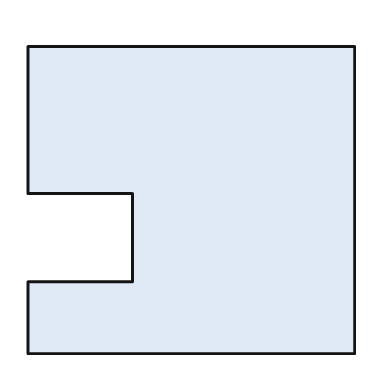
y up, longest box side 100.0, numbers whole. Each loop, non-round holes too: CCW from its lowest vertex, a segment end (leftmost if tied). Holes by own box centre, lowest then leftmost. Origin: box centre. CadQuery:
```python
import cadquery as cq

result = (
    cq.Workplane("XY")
    .moveTo(-50.0, -47.0)
    .lineTo(50.0, -47.0)
    .lineTo(50.0, 47.0)
    .lineTo(-50.0, 47.0)
    .lineTo(-50.0, 2.0)
    .lineTo(-18.0, 2.0)
    .lineTo(-18.0, -25.0)
    .lineTo(-50.0, -25.0)
    .close()
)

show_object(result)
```